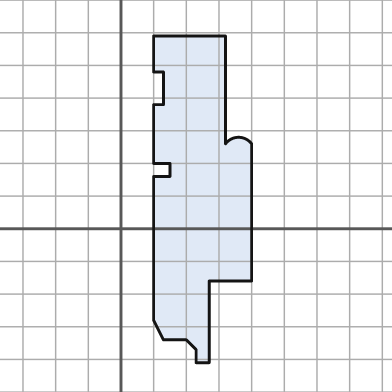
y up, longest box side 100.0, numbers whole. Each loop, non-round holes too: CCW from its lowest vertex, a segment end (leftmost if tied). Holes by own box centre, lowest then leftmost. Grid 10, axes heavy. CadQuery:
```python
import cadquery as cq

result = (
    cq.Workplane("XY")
    .moveTo(23.0, -41.0)
    .lineTo(27.0, -41.0)
    .lineTo(27.0, -16.0)
    .lineTo(40.0, -16.0)
    .lineTo(40.0, 26.0)
    .threePointArc((36.0, 28.0), (32.0, 26.0))
    .lineTo(32.0, 59.0)
    .lineTo(10.0, 59.0)
    .lineTo(10.0, 48.0)
    .lineTo(13.0, 48.0)
    .lineTo(13.0, 38.0)
    .lineTo(10.0, 38.0)
    .lineTo(10.0, 20.0)
    .lineTo(15.0, 20.0)
    .lineTo(15.0, 16.0)
    .lineTo(10.0, 16.0)
    .lineTo(10.0, -28.0)
    .lineTo(13.0, -34.0)
    .lineTo(20.0, -34.0)
    .lineTo(23.0, -37.0)
    .close()
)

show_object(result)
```